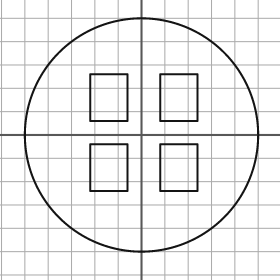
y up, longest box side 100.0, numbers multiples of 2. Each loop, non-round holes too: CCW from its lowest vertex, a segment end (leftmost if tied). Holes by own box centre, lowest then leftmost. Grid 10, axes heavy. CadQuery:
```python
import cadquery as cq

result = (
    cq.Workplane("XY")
    .moveTo(0.0, 0.0)
    .circle(50.0)
    .moveTo(-22.0, -24.0)
    .lineTo(-6.0, -24.0)
    .lineTo(-6.0, -4.0)
    .lineTo(-22.0, -4.0)
    .close()
    .moveTo(8.0, -24.0)
    .lineTo(24.0, -24.0)
    .lineTo(24.0, -4.0)
    .lineTo(8.0, -4.0)
    .close()
    .moveTo(-22.0, 6.0)
    .lineTo(-6.0, 6.0)
    .lineTo(-6.0, 26.0)
    .lineTo(-22.0, 26.0)
    .close()
    .moveTo(8.0, 6.0)
    .lineTo(24.0, 6.0)
    .lineTo(24.0, 26.0)
    .lineTo(8.0, 26.0)
    .close()
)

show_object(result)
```